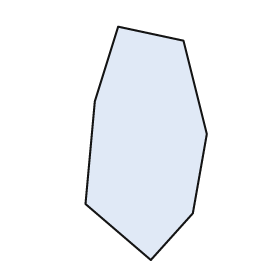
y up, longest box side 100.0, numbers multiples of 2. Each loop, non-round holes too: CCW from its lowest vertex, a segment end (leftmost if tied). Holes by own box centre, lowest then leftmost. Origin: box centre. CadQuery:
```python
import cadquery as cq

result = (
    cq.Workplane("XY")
    .moveTo(2.0, -50.0)
    .lineTo(20.0, -30.0)
    .lineTo(26.0, 4.0)
    .lineTo(16.0, 44.0)
    .lineTo(-12.0, 50.0)
    .lineTo(-22.0, 18.0)
    .lineTo(-26.0, -26.0)
    .close()
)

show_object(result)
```